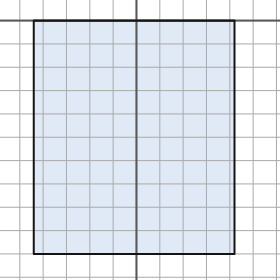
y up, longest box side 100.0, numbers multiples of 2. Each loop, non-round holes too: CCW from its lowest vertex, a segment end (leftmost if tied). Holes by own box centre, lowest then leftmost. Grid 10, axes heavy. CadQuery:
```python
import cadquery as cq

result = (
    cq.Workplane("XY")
    .moveTo(-44.0, -100.0)
    .lineTo(42.0, -100.0)
    .lineTo(42.0, 0.0)
    .lineTo(-44.0, 0.0)
    .close()
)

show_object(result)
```